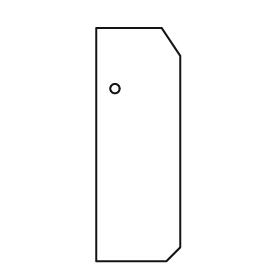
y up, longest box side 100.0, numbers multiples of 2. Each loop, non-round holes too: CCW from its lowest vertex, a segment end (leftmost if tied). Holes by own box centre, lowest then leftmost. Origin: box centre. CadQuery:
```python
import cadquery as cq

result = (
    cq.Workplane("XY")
    .moveTo(-18.0, -50.0)
    .lineTo(12.0, -50.0)
    .lineTo(18.0, -44.0)
    .lineTo(18.0, 38.0)
    .lineTo(10.0, 50.0)
    .lineTo(-18.0, 50.0)
    .close()
    .moveTo(-10.0, 24.0)
    .circle(2.0)
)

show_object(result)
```